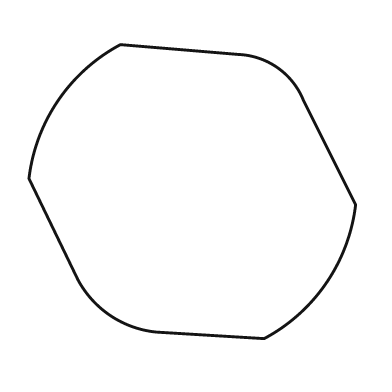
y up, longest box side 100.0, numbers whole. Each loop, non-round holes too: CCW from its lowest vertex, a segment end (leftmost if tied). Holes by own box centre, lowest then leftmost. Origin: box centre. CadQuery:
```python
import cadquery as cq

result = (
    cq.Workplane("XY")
    .moveTo(22.0, -45.0)
    .threePointArc((41.0, -28.0), (50.0, -4.0))
    .lineTo(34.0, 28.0)
    .threePointArc((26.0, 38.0), (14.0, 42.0))
    .lineTo(-22.0, 45.0)
    .threePointArc((-41.0, 28.0), (-50.0, 4.0))
    .lineTo(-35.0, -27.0)
    .threePointArc((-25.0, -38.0), (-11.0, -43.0))
    .close()
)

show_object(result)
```